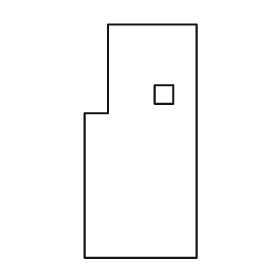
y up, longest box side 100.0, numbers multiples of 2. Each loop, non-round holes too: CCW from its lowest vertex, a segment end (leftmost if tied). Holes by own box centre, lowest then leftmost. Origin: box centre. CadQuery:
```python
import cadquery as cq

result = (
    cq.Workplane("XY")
    .moveTo(-24.0, -50.0)
    .lineTo(24.0, -50.0)
    .lineTo(24.0, 50.0)
    .lineTo(-14.0, 50.0)
    .lineTo(-14.0, 12.0)
    .lineTo(-24.0, 12.0)
    .close()
    .moveTo(6.0, 16.0)
    .lineTo(14.0, 16.0)
    .lineTo(14.0, 24.0)
    .lineTo(6.0, 24.0)
    .close()
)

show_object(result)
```